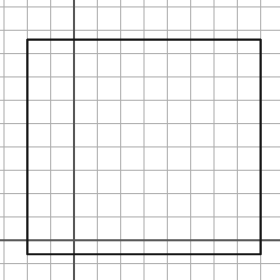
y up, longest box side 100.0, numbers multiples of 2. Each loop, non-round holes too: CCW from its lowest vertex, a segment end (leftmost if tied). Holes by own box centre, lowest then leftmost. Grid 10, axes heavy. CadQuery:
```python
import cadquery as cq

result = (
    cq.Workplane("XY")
    .moveTo(-20.0, -6.0)
    .lineTo(80.0, -6.0)
    .lineTo(80.0, 86.0)
    .lineTo(-20.0, 86.0)
    .close()
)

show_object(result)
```